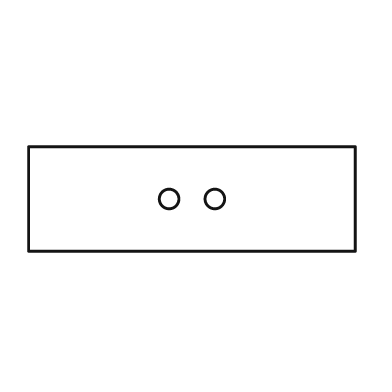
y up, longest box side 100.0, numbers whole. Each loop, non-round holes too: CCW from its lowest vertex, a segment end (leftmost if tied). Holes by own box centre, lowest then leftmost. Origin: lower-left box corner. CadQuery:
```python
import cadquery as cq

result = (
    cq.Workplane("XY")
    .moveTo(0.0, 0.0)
    .lineTo(100.0, 0.0)
    .lineTo(100.0, 32.0)
    .lineTo(0.0, 32.0)
    .close()
    .moveTo(43.0, 16.0)
    .circle(3.0)
    .moveTo(57.0, 16.0)
    .circle(3.0)
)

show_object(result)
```